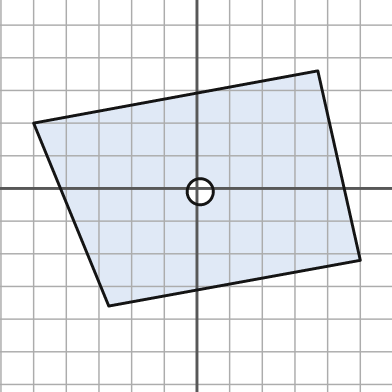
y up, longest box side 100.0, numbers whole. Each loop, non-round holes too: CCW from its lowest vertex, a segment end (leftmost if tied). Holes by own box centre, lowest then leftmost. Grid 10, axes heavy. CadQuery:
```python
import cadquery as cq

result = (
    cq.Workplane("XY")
    .moveTo(-27.0, -36.0)
    .lineTo(50.0, -22.0)
    .lineTo(37.0, 36.0)
    .lineTo(-50.0, 20.0)
    .close()
    .moveTo(1.0, -1.0)
    .circle(4.0)
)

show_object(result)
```